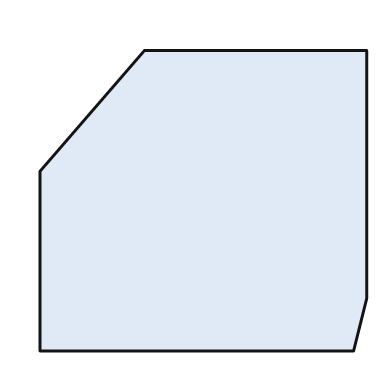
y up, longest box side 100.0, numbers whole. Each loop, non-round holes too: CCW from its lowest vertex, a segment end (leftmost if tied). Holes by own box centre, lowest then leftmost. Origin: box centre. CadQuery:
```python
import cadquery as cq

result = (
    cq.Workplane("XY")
    .moveTo(-50.0, -46.0)
    .lineTo(46.0, -46.0)
    .lineTo(50.0, -30.0)
    .lineTo(50.0, 46.0)
    .lineTo(-18.0, 46.0)
    .lineTo(-50.0, 9.0)
    .close()
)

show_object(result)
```